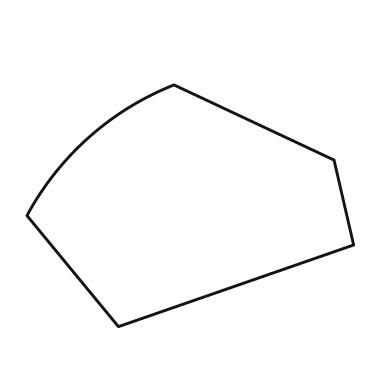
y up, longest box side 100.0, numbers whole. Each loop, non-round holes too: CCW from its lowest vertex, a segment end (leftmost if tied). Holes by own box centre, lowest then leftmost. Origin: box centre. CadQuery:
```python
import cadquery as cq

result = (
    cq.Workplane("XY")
    .moveTo(-22.0, -37.0)
    .lineTo(50.0, -12.0)
    .lineTo(44.0, 14.0)
    .lineTo(-5.0, 37.0)
    .threePointArc((-31.0, 21.0), (-50.0, -3.0))
    .close()
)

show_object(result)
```